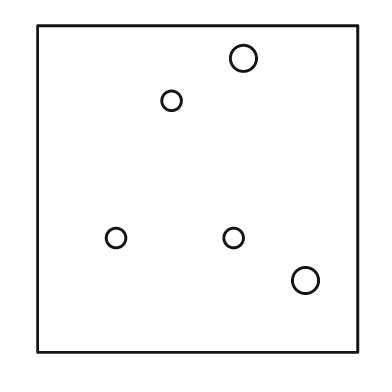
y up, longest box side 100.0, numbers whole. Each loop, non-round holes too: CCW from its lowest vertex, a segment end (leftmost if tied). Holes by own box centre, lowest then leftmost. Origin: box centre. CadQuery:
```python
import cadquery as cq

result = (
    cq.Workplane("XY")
    .moveTo(-49.0, -50.0)
    .lineTo(49.0, -50.0)
    .lineTo(49.0, 50.0)
    .lineTo(-49.0, 50.0)
    .close()
    .moveTo(33.0, -28.0)
    .circle(4.0)
    .moveTo(-25.0, -15.0)
    .circle(3.0)
    .moveTo(11.0, -15.0)
    .circle(3.0)
    .moveTo(-8.0, 27.0)
    .circle(3.0)
    .moveTo(14.0, 40.0)
    .circle(4.0)
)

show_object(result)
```